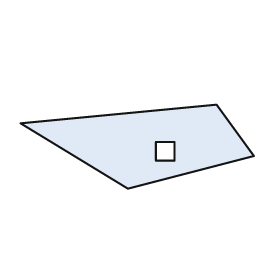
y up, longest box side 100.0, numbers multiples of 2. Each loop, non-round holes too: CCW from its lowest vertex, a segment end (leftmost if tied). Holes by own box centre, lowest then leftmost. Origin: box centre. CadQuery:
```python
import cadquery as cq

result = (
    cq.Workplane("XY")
    .moveTo(-4.0, -18.0)
    .lineTo(50.0, -4.0)
    .lineTo(34.0, 18.0)
    .lineTo(-50.0, 10.0)
    .close()
    .moveTo(8.0, -6.0)
    .lineTo(16.0, -6.0)
    .lineTo(16.0, 2.0)
    .lineTo(8.0, 2.0)
    .close()
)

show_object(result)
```